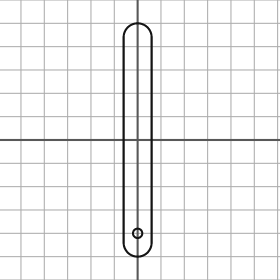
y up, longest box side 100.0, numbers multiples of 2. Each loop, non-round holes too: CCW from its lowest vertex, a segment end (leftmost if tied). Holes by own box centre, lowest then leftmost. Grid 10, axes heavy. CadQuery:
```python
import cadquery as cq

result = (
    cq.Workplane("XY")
    .moveTo(-6.0, -44.0)
    .threePointArc((0.0, -50.0), (6.0, -44.0))
    .lineTo(6.0, 44.0)
    .threePointArc((0.0, 50.0), (-6.0, 44.0))
    .close()
    .moveTo(0.0, -40.0)
    .circle(2.0)
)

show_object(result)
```